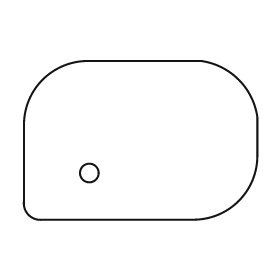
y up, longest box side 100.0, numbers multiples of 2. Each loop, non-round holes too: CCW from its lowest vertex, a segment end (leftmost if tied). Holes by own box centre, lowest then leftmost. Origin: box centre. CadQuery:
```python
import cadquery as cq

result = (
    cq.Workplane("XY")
    .moveTo(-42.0, -34.0)
    .lineTo(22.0, -34.0)
    .threePointArc((42.0, -26.0), (50.0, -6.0))
    .lineTo(50.0, 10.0)
    .threePointArc((42.0, 26.0), (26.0, 34.0))
    .lineTo(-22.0, 34.0)
    .threePointArc((-42.0, 26.0), (-50.0, 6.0))
    .lineTo(-50.0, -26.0)
    .threePointArc((-48.0, -32.0), (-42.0, -34.0))
    .close()
    .moveTo(-22.0, -14.0)
    .circle(4.0)
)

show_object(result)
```